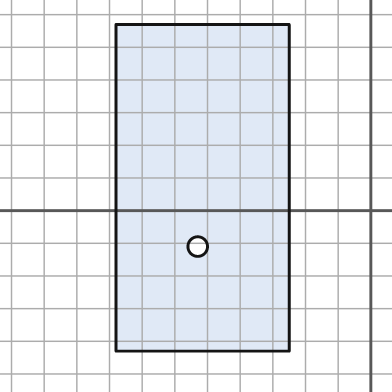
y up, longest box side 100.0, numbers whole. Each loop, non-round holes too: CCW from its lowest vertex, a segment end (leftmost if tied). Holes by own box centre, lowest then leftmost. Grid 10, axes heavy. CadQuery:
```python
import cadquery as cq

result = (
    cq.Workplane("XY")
    .moveTo(-78.0, -43.0)
    .lineTo(-25.0, -43.0)
    .lineTo(-25.0, 57.0)
    .lineTo(-78.0, 57.0)
    .close()
    .moveTo(-53.0, -11.0)
    .circle(3.0)
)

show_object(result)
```